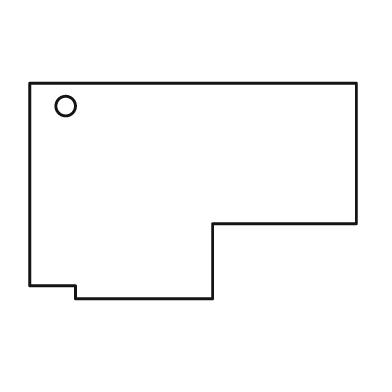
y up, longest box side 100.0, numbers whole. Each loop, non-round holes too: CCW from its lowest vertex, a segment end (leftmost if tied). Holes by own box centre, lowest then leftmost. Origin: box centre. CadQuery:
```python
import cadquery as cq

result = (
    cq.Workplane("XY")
    .moveTo(-36.0, -33.0)
    .lineTo(6.0, -33.0)
    .lineTo(6.0, -10.0)
    .lineTo(50.0, -10.0)
    .lineTo(50.0, 33.0)
    .lineTo(-50.0, 33.0)
    .lineTo(-50.0, -29.0)
    .lineTo(-36.0, -29.0)
    .close()
    .moveTo(-39.0, 26.0)
    .circle(3.0)
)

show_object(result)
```